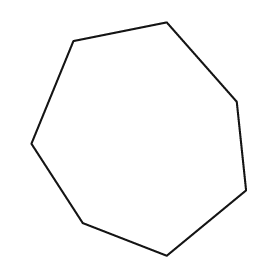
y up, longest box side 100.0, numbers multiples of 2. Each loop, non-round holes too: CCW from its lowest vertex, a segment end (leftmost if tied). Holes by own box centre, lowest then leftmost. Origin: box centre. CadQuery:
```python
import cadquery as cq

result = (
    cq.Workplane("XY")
    .moveTo(12.0, -50.0)
    .lineTo(46.0, -22.0)
    .lineTo(42.0, 16.0)
    .lineTo(12.0, 50.0)
    .lineTo(-28.0, 42.0)
    .lineTo(-46.0, -2.0)
    .lineTo(-24.0, -36.0)
    .close()
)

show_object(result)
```